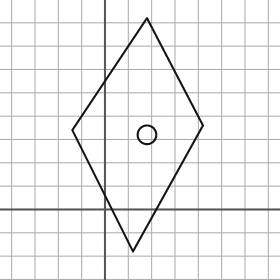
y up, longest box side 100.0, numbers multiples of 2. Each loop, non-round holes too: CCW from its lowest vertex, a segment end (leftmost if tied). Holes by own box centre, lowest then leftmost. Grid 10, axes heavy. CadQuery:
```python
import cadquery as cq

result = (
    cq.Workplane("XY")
    .moveTo(12.0, -18.0)
    .lineTo(42.0, 36.0)
    .lineTo(18.0, 82.0)
    .lineTo(-14.0, 34.0)
    .close()
    .moveTo(18.0, 32.0)
    .circle(4.0)
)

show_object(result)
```